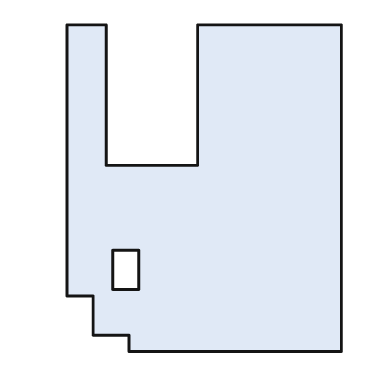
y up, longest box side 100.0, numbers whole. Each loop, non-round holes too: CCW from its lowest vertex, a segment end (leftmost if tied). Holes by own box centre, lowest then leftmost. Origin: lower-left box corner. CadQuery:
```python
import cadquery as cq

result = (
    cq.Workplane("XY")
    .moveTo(19.0, 0.0)
    .lineTo(84.0, 0.0)
    .lineTo(84.0, 100.0)
    .lineTo(40.0, 100.0)
    .lineTo(40.0, 57.0)
    .lineTo(12.0, 57.0)
    .lineTo(12.0, 100.0)
    .lineTo(0.0, 100.0)
    .lineTo(0.0, 17.0)
    .lineTo(8.0, 17.0)
    .lineTo(8.0, 5.0)
    .lineTo(19.0, 5.0)
    .close()
    .moveTo(14.0, 19.0)
    .lineTo(22.0, 19.0)
    .lineTo(22.0, 31.0)
    .lineTo(14.0, 31.0)
    .close()
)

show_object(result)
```